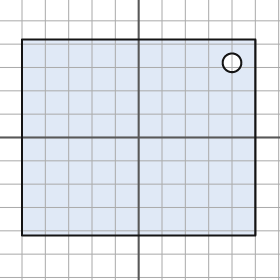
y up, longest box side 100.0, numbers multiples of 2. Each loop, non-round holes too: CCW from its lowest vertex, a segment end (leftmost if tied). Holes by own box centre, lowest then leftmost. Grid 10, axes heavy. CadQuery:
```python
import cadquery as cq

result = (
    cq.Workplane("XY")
    .moveTo(-50.0, -42.0)
    .lineTo(50.0, -42.0)
    .lineTo(50.0, 42.0)
    .lineTo(-50.0, 42.0)
    .close()
    .moveTo(40.0, 32.0)
    .circle(4.0)
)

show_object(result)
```